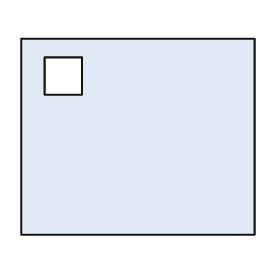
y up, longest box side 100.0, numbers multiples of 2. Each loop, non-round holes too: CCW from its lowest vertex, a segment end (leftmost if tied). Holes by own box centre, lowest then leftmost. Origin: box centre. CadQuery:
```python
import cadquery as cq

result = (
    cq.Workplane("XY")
    .moveTo(-50.0, -42.0)
    .lineTo(50.0, -42.0)
    .lineTo(50.0, 42.0)
    .lineTo(-50.0, 42.0)
    .close()
    .moveTo(-40.0, 18.0)
    .lineTo(-24.0, 18.0)
    .lineTo(-24.0, 34.0)
    .lineTo(-40.0, 34.0)
    .close()
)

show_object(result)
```